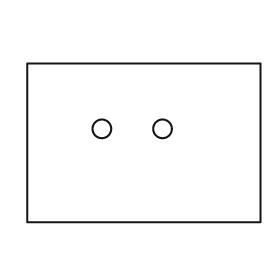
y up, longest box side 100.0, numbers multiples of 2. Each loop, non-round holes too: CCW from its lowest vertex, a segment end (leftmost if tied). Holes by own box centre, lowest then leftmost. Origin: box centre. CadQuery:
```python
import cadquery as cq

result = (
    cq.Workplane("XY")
    .moveTo(-50.0, -34.0)
    .lineTo(50.0, -34.0)
    .lineTo(50.0, 34.0)
    .lineTo(-50.0, 34.0)
    .close()
    .moveTo(-18.0, 6.0)
    .circle(4.0)
    .moveTo(8.0, 6.0)
    .circle(4.0)
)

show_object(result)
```